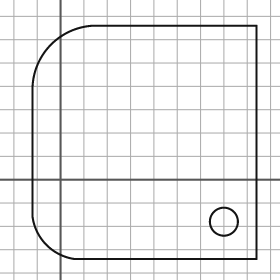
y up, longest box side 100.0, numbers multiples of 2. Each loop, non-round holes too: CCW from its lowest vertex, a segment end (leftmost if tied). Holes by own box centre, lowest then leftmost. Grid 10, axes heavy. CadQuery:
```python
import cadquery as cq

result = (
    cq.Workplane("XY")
    .moveTo(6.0, -34.0)
    .lineTo(84.0, -34.0)
    .lineTo(84.0, 66.0)
    .lineTo(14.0, 66.0)
    .threePointArc((-4.0, 58.0), (-12.0, 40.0))
    .lineTo(-12.0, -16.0)
    .threePointArc((-6.0, -28.0), (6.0, -34.0))
    .close()
    .moveTo(70.0, -18.0)
    .circle(6.0)
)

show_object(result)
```